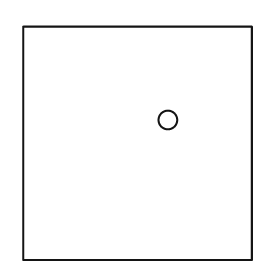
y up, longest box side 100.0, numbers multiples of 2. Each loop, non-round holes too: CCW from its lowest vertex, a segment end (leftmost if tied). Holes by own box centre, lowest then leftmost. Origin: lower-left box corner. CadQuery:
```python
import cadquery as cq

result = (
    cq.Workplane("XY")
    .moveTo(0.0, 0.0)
    .lineTo(98.0, 0.0)
    .lineTo(98.0, 100.0)
    .lineTo(0.0, 100.0)
    .close()
    .moveTo(62.0, 60.0)
    .circle(4.0)
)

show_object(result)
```